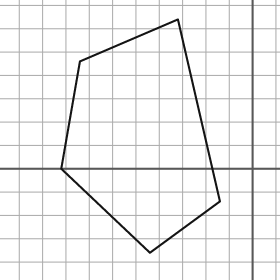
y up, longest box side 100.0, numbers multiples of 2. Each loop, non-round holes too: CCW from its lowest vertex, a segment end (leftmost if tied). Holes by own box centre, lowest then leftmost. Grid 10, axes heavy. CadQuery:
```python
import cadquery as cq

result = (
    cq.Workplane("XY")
    .moveTo(-44.0, -36.0)
    .lineTo(-14.0, -14.0)
    .lineTo(-32.0, 64.0)
    .lineTo(-74.0, 46.0)
    .lineTo(-82.0, 0.0)
    .close()
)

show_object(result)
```